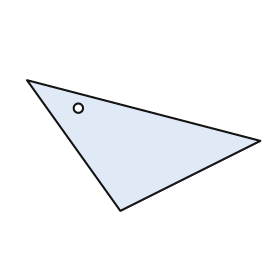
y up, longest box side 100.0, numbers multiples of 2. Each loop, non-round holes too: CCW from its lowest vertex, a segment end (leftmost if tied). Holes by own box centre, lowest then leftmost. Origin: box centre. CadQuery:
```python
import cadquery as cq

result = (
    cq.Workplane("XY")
    .moveTo(-10.0, -28.0)
    .lineTo(50.0, 2.0)
    .lineTo(-50.0, 28.0)
    .close()
    .moveTo(-28.0, 16.0)
    .circle(2.0)
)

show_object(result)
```